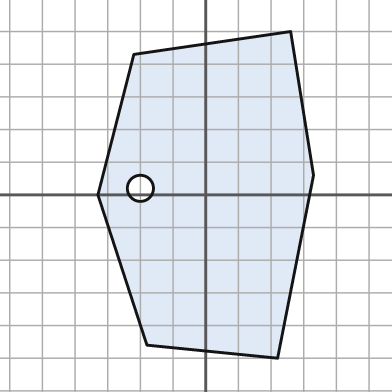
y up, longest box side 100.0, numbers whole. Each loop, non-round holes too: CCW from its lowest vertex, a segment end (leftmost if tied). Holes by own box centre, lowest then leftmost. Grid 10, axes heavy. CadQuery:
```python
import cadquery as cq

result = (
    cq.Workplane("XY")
    .moveTo(22.0, -50.0)
    .lineTo(33.0, 6.0)
    .lineTo(26.0, 50.0)
    .lineTo(-22.0, 43.0)
    .lineTo(-33.0, 0.0)
    .lineTo(-18.0, -46.0)
    .close()
    .moveTo(-20.0, 2.0)
    .circle(4.0)
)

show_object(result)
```